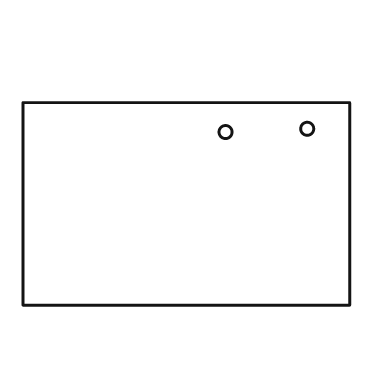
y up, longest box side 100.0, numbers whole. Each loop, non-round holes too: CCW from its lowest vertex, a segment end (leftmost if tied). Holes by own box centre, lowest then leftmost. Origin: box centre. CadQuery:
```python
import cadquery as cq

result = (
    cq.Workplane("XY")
    .moveTo(-50.0, -31.0)
    .lineTo(50.0, -31.0)
    .lineTo(50.0, 31.0)
    .lineTo(-50.0, 31.0)
    .close()
    .moveTo(12.0, 22.0)
    .circle(2.0)
    .moveTo(37.0, 23.0)
    .circle(2.0)
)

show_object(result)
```